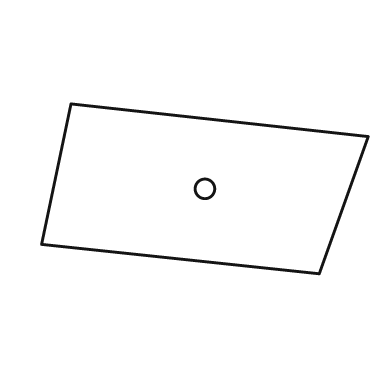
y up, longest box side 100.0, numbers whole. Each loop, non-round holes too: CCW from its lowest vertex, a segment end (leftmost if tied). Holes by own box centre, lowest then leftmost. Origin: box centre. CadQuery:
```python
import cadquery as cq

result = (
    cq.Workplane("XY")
    .moveTo(35.0, -26.0)
    .lineTo(50.0, 16.0)
    .lineTo(-41.0, 26.0)
    .lineTo(-50.0, -17.0)
    .close()
    .moveTo(0.0, 0.0)
    .circle(3.0)
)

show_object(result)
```